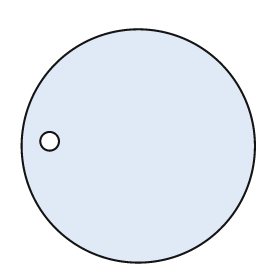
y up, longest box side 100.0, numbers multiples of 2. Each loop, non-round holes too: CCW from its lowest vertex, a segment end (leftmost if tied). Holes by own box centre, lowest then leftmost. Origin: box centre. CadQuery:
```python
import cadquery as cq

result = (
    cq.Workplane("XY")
    .moveTo(0.0, 0.0)
    .circle(50.0)
    .moveTo(-38.0, 2.0)
    .circle(4.0)
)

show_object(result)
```